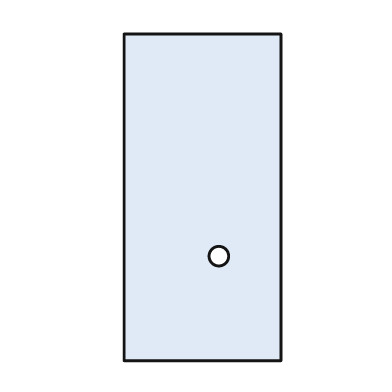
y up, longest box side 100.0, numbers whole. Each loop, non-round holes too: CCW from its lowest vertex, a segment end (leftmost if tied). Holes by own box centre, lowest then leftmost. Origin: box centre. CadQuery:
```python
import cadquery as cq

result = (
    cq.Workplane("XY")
    .moveTo(-24.0, -50.0)
    .lineTo(24.0, -50.0)
    .lineTo(24.0, 50.0)
    .lineTo(-24.0, 50.0)
    .close()
    .moveTo(5.0, -18.0)
    .circle(3.0)
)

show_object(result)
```